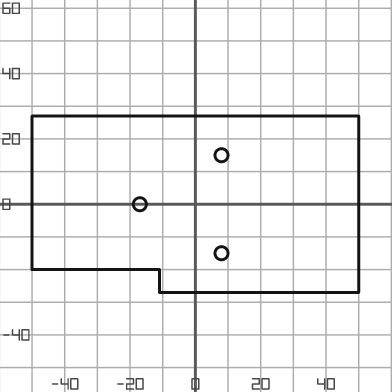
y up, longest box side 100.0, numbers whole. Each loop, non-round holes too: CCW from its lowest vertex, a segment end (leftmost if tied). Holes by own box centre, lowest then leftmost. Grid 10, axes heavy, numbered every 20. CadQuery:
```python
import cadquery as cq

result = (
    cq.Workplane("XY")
    .moveTo(-11.0, -27.0)
    .lineTo(50.0, -27.0)
    .lineTo(50.0, 27.0)
    .lineTo(-50.0, 27.0)
    .lineTo(-50.0, -20.0)
    .lineTo(-11.0, -20.0)
    .close()
    .moveTo(8.0, -15.0)
    .circle(2.0)
    .moveTo(-17.0, 0.0)
    .circle(2.0)
    .moveTo(8.0, 15.0)
    .circle(2.0)
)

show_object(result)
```